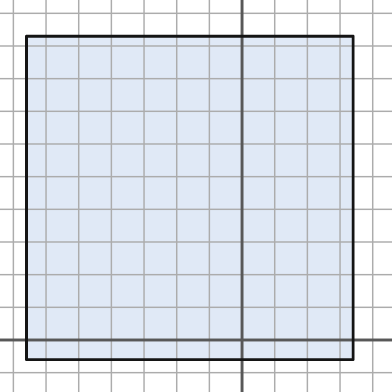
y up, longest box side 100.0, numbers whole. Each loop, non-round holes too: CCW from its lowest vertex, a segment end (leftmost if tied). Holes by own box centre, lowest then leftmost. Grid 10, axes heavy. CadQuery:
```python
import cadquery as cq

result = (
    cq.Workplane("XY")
    .moveTo(-66.0, -6.0)
    .lineTo(34.0, -6.0)
    .lineTo(34.0, 93.0)
    .lineTo(-66.0, 93.0)
    .close()
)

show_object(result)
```